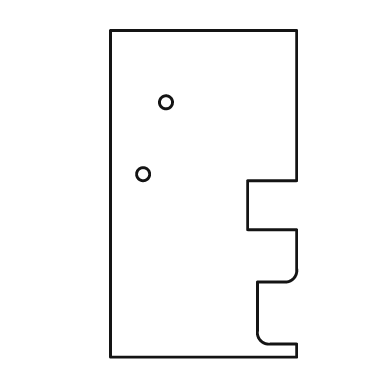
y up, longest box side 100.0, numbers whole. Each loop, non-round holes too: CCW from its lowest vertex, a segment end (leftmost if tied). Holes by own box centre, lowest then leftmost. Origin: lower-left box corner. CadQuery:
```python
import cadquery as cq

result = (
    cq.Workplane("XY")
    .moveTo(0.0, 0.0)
    .lineTo(57.0, 0.0)
    .lineTo(57.0, 4.0)
    .lineTo(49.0, 4.0)
    .threePointArc((46.0, 5.0), (45.0, 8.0))
    .lineTo(45.0, 23.0)
    .lineTo(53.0, 23.0)
    .threePointArc((56.0, 24.0), (57.0, 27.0))
    .lineTo(57.0, 39.0)
    .lineTo(42.0, 39.0)
    .lineTo(42.0, 54.0)
    .lineTo(57.0, 54.0)
    .lineTo(57.0, 100.0)
    .lineTo(0.0, 100.0)
    .close()
    .moveTo(10.0, 56.0)
    .circle(2.0)
    .moveTo(17.0, 78.0)
    .circle(2.0)
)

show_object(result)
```